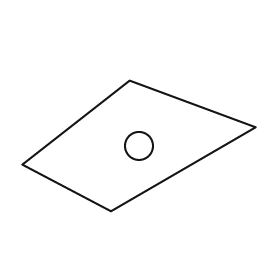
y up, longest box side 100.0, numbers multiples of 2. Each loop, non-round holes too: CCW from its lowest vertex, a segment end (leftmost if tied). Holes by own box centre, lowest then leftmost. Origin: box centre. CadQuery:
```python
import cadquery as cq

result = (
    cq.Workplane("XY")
    .moveTo(-12.0, -28.0)
    .lineTo(50.0, 8.0)
    .lineTo(-4.0, 28.0)
    .lineTo(-50.0, -8.0)
    .close()
    .moveTo(0.0, 0.0)
    .circle(6.0)
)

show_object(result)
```